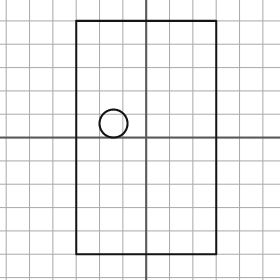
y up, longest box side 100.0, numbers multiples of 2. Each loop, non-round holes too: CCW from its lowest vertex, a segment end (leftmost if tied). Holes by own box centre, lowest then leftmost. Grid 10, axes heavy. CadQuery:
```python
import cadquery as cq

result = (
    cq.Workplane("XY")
    .moveTo(-30.0, -50.0)
    .lineTo(30.0, -50.0)
    .lineTo(30.0, 50.0)
    .lineTo(-30.0, 50.0)
    .close()
    .moveTo(-14.0, 6.0)
    .circle(6.0)
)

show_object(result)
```